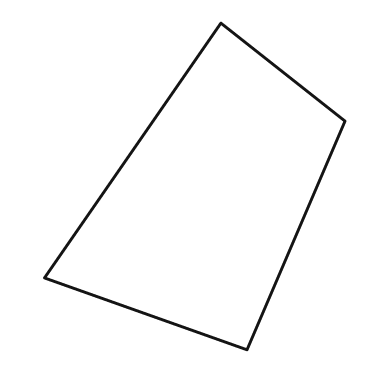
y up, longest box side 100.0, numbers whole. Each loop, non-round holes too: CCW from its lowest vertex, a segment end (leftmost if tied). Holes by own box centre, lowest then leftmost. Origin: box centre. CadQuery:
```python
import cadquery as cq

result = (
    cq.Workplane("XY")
    .moveTo(16.0, -50.0)
    .lineTo(46.0, 20.0)
    .lineTo(8.0, 50.0)
    .lineTo(-46.0, -28.0)
    .close()
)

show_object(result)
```